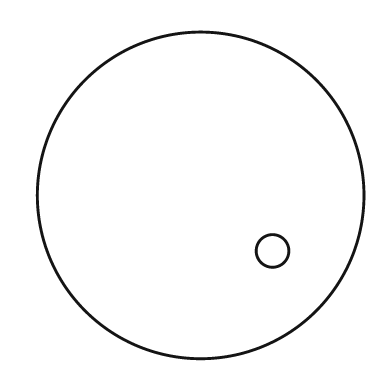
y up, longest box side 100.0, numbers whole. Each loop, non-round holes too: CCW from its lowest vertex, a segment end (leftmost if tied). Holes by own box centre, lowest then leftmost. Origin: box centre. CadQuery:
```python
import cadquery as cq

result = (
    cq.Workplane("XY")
    .moveTo(0.0, 0.0)
    .circle(50.0)
    .moveTo(22.0, -17.0)
    .circle(5.0)
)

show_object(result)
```